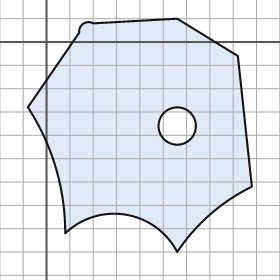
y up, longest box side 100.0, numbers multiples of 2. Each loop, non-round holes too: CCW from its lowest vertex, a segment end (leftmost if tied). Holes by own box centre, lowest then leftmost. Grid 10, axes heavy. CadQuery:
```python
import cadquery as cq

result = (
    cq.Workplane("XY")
    .moveTo(56.0, -90.0)
    .threePointArc((70.0, -74.0), (88.0, -62.0))
    .lineTo(82.0, -6.0)
    .lineTo(56.0, 10.0)
    .lineTo(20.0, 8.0)
    .threePointArc((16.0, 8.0), (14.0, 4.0))
    .lineTo(-8.0, -28.0)
    .threePointArc((4.0, -54.0), (8.0, -82.0))
    .threePointArc((34.0, -74.0), (56.0, -90.0))
    .close()
    .moveTo(56.0, -36.0)
    .circle(8.0)
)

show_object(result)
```